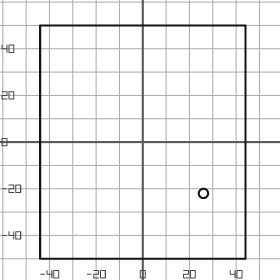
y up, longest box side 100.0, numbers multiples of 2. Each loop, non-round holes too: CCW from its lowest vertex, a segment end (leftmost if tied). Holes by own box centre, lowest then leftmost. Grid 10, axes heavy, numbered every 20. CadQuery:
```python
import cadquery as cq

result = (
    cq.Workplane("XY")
    .moveTo(-44.0, -50.0)
    .lineTo(44.0, -50.0)
    .lineTo(44.0, 50.0)
    .lineTo(-44.0, 50.0)
    .close()
    .moveTo(26.0, -22.0)
    .circle(2.0)
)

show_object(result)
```